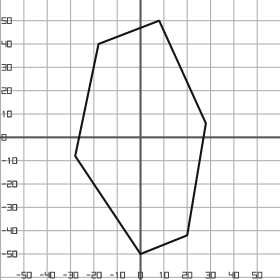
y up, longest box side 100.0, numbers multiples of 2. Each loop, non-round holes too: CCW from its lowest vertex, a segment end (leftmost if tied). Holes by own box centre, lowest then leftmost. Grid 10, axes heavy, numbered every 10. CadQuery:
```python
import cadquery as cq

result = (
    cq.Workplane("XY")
    .moveTo(0.0, -50.0)
    .lineTo(20.0, -42.0)
    .lineTo(28.0, 6.0)
    .lineTo(8.0, 50.0)
    .lineTo(-18.0, 40.0)
    .lineTo(-28.0, -8.0)
    .close()
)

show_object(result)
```